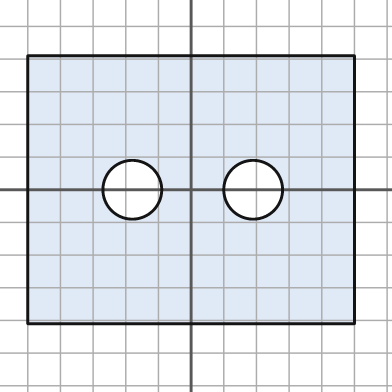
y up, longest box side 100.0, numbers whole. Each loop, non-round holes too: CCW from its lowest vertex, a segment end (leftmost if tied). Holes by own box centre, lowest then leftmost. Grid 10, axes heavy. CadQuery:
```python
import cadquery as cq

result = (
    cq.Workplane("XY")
    .moveTo(-50.0, -41.0)
    .lineTo(50.0, -41.0)
    .lineTo(50.0, 41.0)
    .lineTo(-50.0, 41.0)
    .close()
    .moveTo(-18.0, 0.0)
    .circle(9.0)
    .moveTo(19.0, 0.0)
    .circle(9.0)
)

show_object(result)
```